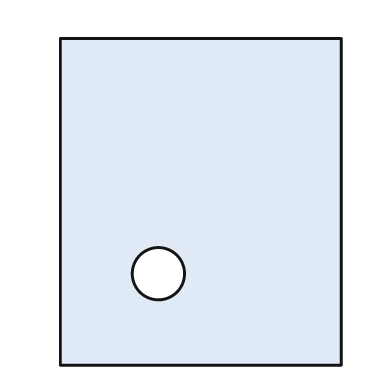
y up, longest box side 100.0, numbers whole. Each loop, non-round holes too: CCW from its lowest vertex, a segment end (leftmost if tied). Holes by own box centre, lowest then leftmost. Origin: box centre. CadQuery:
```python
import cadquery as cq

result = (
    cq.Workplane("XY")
    .moveTo(-43.0, -50.0)
    .lineTo(43.0, -50.0)
    .lineTo(43.0, 50.0)
    .lineTo(-43.0, 50.0)
    .close()
    .moveTo(-13.0, -22.0)
    .circle(8.0)
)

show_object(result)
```